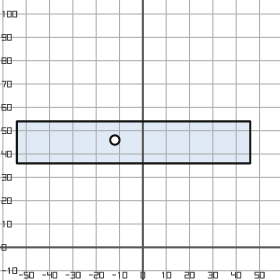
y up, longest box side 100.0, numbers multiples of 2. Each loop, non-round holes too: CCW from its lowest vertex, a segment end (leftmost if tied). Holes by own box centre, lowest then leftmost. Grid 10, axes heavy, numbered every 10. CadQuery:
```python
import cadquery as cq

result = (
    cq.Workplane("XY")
    .moveTo(-54.0, 36.0)
    .lineTo(46.0, 36.0)
    .lineTo(46.0, 54.0)
    .lineTo(-54.0, 54.0)
    .close()
    .moveTo(-12.0, 46.0)
    .circle(2.0)
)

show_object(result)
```